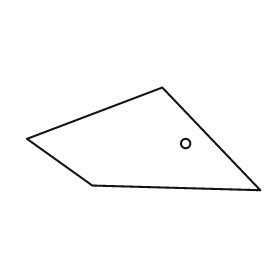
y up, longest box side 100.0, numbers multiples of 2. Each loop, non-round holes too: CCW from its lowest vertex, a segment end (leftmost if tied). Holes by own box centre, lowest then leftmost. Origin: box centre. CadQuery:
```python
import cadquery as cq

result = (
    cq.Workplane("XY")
    .moveTo(50.0, -22.0)
    .lineTo(8.0, 22.0)
    .lineTo(-50.0, 0.0)
    .lineTo(-22.0, -20.0)
    .close()
    .moveTo(18.0, -2.0)
    .circle(2.0)
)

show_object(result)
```